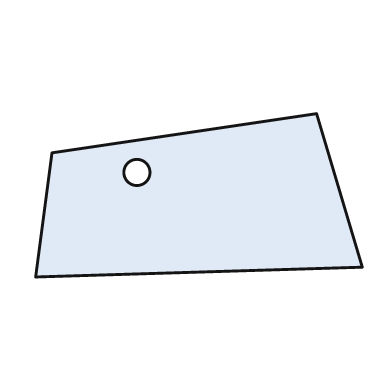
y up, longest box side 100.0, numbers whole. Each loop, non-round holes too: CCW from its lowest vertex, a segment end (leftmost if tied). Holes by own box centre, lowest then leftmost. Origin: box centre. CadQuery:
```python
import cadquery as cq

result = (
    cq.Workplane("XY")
    .moveTo(-50.0, -25.0)
    .lineTo(50.0, -22.0)
    .lineTo(36.0, 25.0)
    .lineTo(-45.0, 13.0)
    .close()
    .moveTo(-19.0, 7.0)
    .circle(4.0)
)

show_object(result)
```